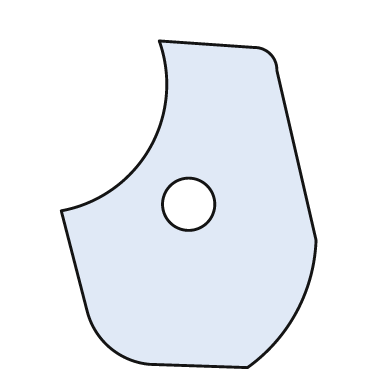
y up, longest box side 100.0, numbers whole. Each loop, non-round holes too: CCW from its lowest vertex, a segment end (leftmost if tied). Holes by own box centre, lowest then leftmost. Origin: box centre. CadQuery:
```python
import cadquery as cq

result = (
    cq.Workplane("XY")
    .moveTo(18.0, -50.0)
    .threePointArc((33.0, -33.0), (39.0, -11.0))
    .lineTo(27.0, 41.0)
    .threePointArc((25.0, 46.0), (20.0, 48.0))
    .lineTo(-9.0, 50.0)
    .threePointArc((-12.0, 17.0), (-39.0, -2.0))
    .lineTo(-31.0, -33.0)
    .threePointArc((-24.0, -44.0), (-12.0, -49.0))
    .close()
    .moveTo(0.0, 0.0)
    .circle(8.0)
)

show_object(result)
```